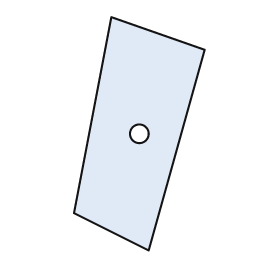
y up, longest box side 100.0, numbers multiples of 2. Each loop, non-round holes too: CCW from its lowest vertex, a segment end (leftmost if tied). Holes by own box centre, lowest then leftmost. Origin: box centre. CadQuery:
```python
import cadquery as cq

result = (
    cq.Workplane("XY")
    .moveTo(4.0, -50.0)
    .lineTo(28.0, 36.0)
    .lineTo(-12.0, 50.0)
    .lineTo(-28.0, -34.0)
    .close()
    .moveTo(0.0, 0.0)
    .circle(4.0)
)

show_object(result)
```